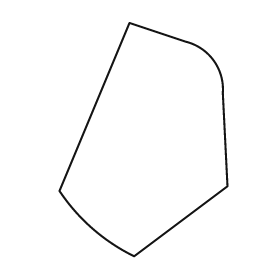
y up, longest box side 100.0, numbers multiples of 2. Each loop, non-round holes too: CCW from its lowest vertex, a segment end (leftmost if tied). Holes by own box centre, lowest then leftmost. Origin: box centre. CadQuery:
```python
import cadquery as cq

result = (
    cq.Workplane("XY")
    .moveTo(-4.0, -50.0)
    .lineTo(36.0, -20.0)
    .lineTo(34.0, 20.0)
    .threePointArc((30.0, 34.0), (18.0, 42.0))
    .lineTo(-6.0, 50.0)
    .lineTo(-36.0, -22.0)
    .threePointArc((-22.0, -38.0), (-4.0, -50.0))
    .close()
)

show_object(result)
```